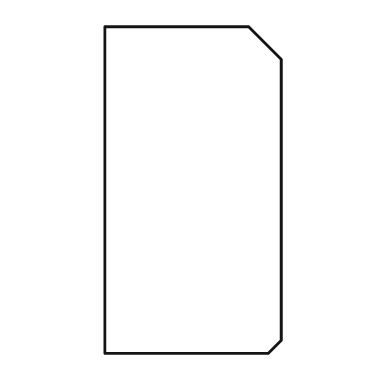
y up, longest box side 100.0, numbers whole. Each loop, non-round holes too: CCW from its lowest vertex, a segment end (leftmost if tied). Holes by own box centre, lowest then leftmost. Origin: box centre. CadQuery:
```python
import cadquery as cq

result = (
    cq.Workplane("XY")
    .moveTo(-27.0, -50.0)
    .lineTo(23.0, -50.0)
    .lineTo(27.0, -46.0)
    .lineTo(27.0, 40.0)
    .lineTo(17.0, 50.0)
    .lineTo(-27.0, 50.0)
    .close()
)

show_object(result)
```